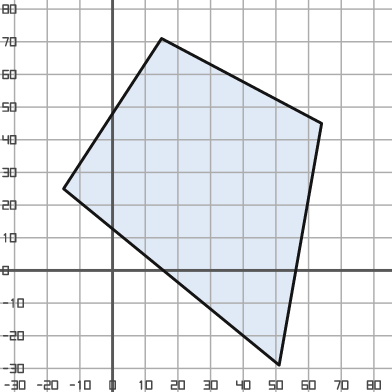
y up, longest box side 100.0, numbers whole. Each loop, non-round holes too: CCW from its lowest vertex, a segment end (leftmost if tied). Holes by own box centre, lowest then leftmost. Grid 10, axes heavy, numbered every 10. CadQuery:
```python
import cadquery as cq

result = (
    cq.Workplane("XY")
    .moveTo(51.0, -29.0)
    .lineTo(64.0, 45.0)
    .lineTo(15.0, 71.0)
    .lineTo(-15.0, 25.0)
    .close()
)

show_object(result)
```